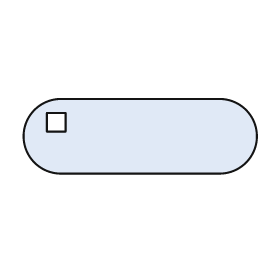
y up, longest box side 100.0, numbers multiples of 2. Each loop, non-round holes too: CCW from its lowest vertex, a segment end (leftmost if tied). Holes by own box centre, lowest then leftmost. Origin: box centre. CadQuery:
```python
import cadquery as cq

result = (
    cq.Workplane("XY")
    .moveTo(-34.0, -16.0)
    .lineTo(34.0, -16.0)
    .threePointArc((50.0, 0.0), (34.0, 16.0))
    .lineTo(-34.0, 16.0)
    .threePointArc((-50.0, 0.0), (-34.0, -16.0))
    .close()
    .moveTo(-40.0, 2.0)
    .lineTo(-32.0, 2.0)
    .lineTo(-32.0, 10.0)
    .lineTo(-40.0, 10.0)
    .close()
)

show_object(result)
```